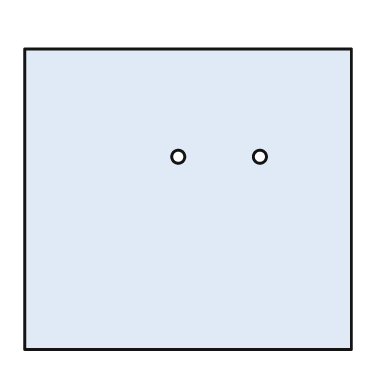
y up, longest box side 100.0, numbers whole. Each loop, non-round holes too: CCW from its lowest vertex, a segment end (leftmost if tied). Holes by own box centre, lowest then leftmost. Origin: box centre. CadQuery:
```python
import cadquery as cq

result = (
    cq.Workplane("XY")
    .moveTo(-50.0, -46.0)
    .lineTo(50.0, -46.0)
    .lineTo(50.0, 46.0)
    .lineTo(-50.0, 46.0)
    .close()
    .moveTo(-3.0, 13.0)
    .circle(2.0)
    .moveTo(22.0, 13.0)
    .circle(2.0)
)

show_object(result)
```